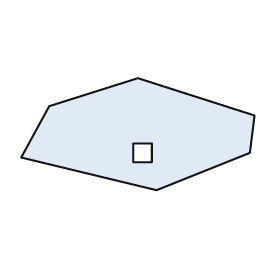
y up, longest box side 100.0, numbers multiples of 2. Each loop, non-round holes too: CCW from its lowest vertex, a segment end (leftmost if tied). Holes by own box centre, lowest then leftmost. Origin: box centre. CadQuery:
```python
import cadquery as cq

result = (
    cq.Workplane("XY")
    .moveTo(8.0, -24.0)
    .lineTo(48.0, -8.0)
    .lineTo(50.0, 8.0)
    .lineTo(0.0, 24.0)
    .lineTo(-38.0, 12.0)
    .lineTo(-50.0, -10.0)
    .close()
    .moveTo(-2.0, -12.0)
    .lineTo(6.0, -12.0)
    .lineTo(6.0, -4.0)
    .lineTo(-2.0, -4.0)
    .close()
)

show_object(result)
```